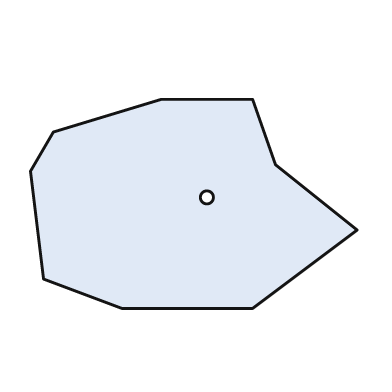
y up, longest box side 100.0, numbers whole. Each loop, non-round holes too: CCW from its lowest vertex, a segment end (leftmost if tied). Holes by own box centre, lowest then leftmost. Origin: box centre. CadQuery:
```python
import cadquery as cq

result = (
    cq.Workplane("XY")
    .moveTo(-22.0, -32.0)
    .lineTo(18.0, -32.0)
    .lineTo(50.0, -8.0)
    .lineTo(25.0, 12.0)
    .lineTo(18.0, 32.0)
    .lineTo(-10.0, 32.0)
    .lineTo(-43.0, 22.0)
    .lineTo(-50.0, 10.0)
    .lineTo(-46.0, -23.0)
    .close()
    .moveTo(4.0, 2.0)
    .circle(2.0)
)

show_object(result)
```